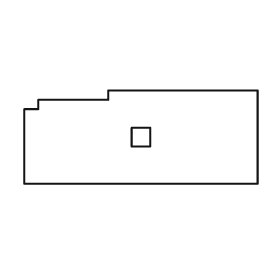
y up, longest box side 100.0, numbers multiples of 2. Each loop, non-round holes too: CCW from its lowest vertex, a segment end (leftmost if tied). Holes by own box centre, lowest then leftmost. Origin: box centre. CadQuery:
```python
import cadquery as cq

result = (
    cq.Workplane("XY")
    .moveTo(-50.0, -20.0)
    .lineTo(50.0, -20.0)
    .lineTo(50.0, 20.0)
    .lineTo(-14.0, 20.0)
    .lineTo(-14.0, 16.0)
    .lineTo(-44.0, 16.0)
    .lineTo(-44.0, 12.0)
    .lineTo(-50.0, 12.0)
    .close()
    .moveTo(-4.0, -4.0)
    .lineTo(4.0, -4.0)
    .lineTo(4.0, 4.0)
    .lineTo(-4.0, 4.0)
    .close()
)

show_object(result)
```